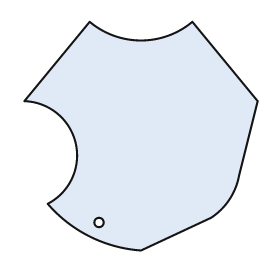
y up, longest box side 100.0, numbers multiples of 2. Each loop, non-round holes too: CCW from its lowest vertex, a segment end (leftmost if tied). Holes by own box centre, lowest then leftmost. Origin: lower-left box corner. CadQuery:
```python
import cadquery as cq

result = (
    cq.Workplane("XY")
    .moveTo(50.0, 0.0)
    .lineTo(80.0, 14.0)
    .threePointArc((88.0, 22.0), (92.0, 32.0))
    .lineTo(100.0, 64.0)
    .lineTo(72.0, 98.0)
    .threePointArc((50.0, 90.0), (28.0, 98.0))
    .lineTo(0.0, 64.0)
    .threePointArc((22.0, 46.0), (10.0, 20.0))
    .threePointArc((28.0, 6.0), (50.0, 0.0))
    .close()
    .moveTo(32.0, 12.0)
    .circle(2.0)
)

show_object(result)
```